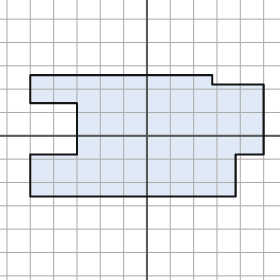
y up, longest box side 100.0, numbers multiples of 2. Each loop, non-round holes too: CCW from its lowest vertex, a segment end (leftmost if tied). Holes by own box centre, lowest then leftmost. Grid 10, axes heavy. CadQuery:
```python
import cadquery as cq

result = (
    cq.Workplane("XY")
    .moveTo(-50.0, -26.0)
    .lineTo(38.0, -26.0)
    .lineTo(38.0, -8.0)
    .lineTo(50.0, -8.0)
    .lineTo(50.0, 22.0)
    .lineTo(28.0, 22.0)
    .lineTo(28.0, 26.0)
    .lineTo(-50.0, 26.0)
    .lineTo(-50.0, 14.0)
    .lineTo(-30.0, 14.0)
    .lineTo(-30.0, -8.0)
    .lineTo(-50.0, -8.0)
    .close()
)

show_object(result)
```